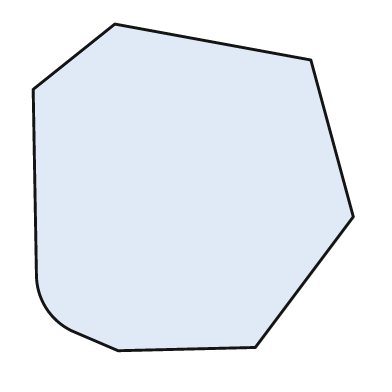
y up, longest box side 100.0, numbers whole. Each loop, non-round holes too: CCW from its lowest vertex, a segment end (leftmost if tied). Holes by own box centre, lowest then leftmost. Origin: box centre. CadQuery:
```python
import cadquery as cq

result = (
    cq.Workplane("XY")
    .moveTo(-23.0, -50.0)
    .lineTo(19.0, -49.0)
    .lineTo(49.0, -9.0)
    .lineTo(36.0, 39.0)
    .lineTo(-24.0, 50.0)
    .lineTo(-49.0, 30.0)
    .lineTo(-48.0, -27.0)
    .threePointArc((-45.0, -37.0), (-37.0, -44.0))
    .close()
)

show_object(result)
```